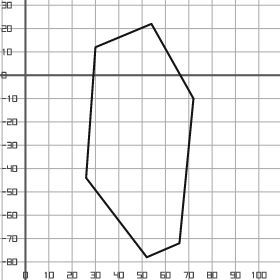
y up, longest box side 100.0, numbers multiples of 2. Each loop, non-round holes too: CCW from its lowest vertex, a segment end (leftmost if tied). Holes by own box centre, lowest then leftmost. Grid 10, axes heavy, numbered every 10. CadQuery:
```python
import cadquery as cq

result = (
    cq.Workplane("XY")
    .moveTo(52.0, -78.0)
    .lineTo(66.0, -72.0)
    .lineTo(72.0, -10.0)
    .lineTo(54.0, 22.0)
    .lineTo(30.0, 12.0)
    .lineTo(26.0, -44.0)
    .close()
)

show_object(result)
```